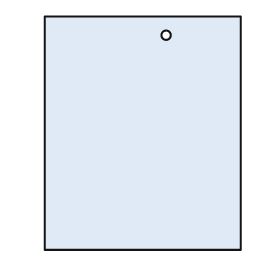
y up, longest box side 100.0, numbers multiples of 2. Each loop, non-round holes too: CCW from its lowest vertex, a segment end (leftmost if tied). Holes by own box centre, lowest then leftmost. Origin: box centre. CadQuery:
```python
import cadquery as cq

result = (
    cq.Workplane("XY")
    .moveTo(-42.0, -50.0)
    .lineTo(42.0, -50.0)
    .lineTo(42.0, 50.0)
    .lineTo(-42.0, 50.0)
    .close()
    .moveTo(10.0, 42.0)
    .circle(2.0)
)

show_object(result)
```